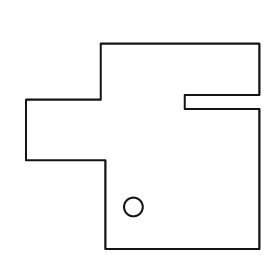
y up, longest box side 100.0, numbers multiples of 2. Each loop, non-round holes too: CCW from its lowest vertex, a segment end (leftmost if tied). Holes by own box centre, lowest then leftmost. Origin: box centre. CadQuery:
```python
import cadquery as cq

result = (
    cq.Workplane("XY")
    .moveTo(-16.0, -44.0)
    .lineTo(50.0, -44.0)
    .lineTo(50.0, 16.0)
    .lineTo(18.0, 16.0)
    .lineTo(18.0, 22.0)
    .lineTo(50.0, 22.0)
    .lineTo(50.0, 44.0)
    .lineTo(-18.0, 44.0)
    .lineTo(-18.0, 20.0)
    .lineTo(-50.0, 20.0)
    .lineTo(-50.0, -6.0)
    .lineTo(-16.0, -6.0)
    .close()
    .moveTo(-4.0, -26.0)
    .circle(4.0)
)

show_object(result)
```